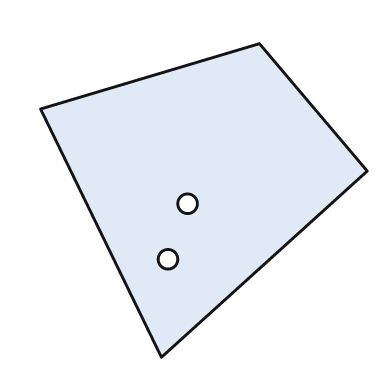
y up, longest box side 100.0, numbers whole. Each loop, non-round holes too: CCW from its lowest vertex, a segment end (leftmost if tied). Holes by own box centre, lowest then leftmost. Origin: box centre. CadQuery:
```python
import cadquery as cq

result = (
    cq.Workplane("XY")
    .moveTo(-13.0, -48.0)
    .lineTo(50.0, 9.0)
    .lineTo(17.0, 48.0)
    .lineTo(-50.0, 28.0)
    .close()
    .moveTo(-11.0, -18.0)
    .circle(3.0)
    .moveTo(-5.0, -1.0)
    .circle(3.0)
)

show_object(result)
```